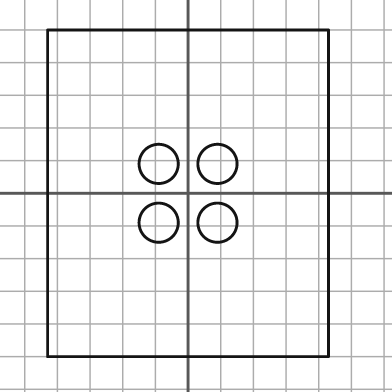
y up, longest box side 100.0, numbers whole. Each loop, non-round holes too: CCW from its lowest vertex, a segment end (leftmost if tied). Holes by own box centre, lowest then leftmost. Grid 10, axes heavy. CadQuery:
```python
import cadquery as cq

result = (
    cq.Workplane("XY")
    .moveTo(-43.0, -50.0)
    .lineTo(43.0, -50.0)
    .lineTo(43.0, 50.0)
    .lineTo(-43.0, 50.0)
    .close()
    .moveTo(-9.0, -9.0)
    .circle(6.0)
    .moveTo(9.0, -9.0)
    .circle(6.0)
    .moveTo(-9.0, 9.0)
    .circle(6.0)
    .moveTo(9.0, 9.0)
    .circle(6.0)
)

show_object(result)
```